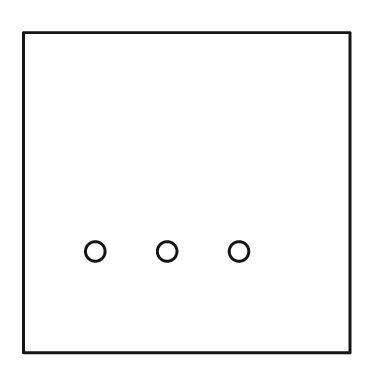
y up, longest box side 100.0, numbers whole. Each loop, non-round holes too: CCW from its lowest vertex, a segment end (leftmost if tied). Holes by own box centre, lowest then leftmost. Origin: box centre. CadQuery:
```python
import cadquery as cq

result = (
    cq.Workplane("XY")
    .moveTo(-50.0, -49.0)
    .lineTo(50.0, -49.0)
    .lineTo(50.0, 49.0)
    .lineTo(-50.0, 49.0)
    .close()
    .moveTo(-28.0, -18.0)
    .circle(3.0)
    .moveTo(-6.0, -18.0)
    .circle(3.0)
    .moveTo(16.0, -18.0)
    .circle(3.0)
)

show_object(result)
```